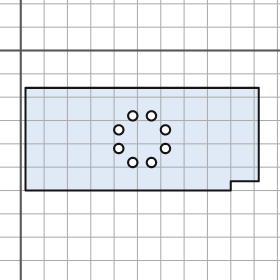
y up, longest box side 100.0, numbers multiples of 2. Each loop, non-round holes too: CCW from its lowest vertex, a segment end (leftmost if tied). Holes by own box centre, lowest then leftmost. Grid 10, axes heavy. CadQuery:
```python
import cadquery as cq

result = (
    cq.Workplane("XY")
    .moveTo(2.0, -60.0)
    .lineTo(90.0, -60.0)
    .lineTo(90.0, -56.0)
    .lineTo(102.0, -56.0)
    .lineTo(102.0, -16.0)
    .lineTo(2.0, -16.0)
    .close()
    .moveTo(48.0, -48.0)
    .circle(2.0)
    .moveTo(56.0, -48.0)
    .circle(2.0)
    .moveTo(42.0, -42.0)
    .circle(2.0)
    .moveTo(62.0, -42.0)
    .circle(2.0)
    .moveTo(42.0, -34.0)
    .circle(2.0)
    .moveTo(62.0, -34.0)
    .circle(2.0)
    .moveTo(48.0, -28.0)
    .circle(2.0)
    .moveTo(56.0, -28.0)
    .circle(2.0)
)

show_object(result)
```